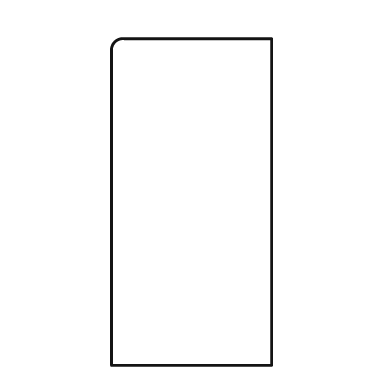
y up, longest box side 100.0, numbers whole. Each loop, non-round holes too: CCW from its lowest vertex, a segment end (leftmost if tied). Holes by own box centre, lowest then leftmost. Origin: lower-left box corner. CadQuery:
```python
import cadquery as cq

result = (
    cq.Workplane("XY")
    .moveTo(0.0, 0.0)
    .lineTo(49.0, 0.0)
    .lineTo(49.0, 100.0)
    .lineTo(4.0, 100.0)
    .threePointArc((1.0, 99.0), (0.0, 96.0))
    .close()
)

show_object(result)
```